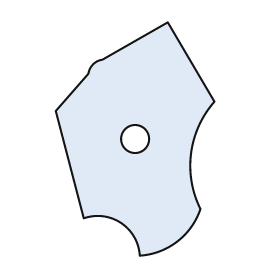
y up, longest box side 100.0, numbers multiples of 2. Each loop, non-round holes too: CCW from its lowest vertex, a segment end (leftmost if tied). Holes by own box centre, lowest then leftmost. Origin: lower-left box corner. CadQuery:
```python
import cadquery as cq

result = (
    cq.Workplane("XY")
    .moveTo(36.0, 0.0)
    .threePointArc((52.0, 6.0), (62.0, 20.0))
    .threePointArc((58.0, 44.0), (68.0, 66.0))
    .lineTo(48.0, 100.0)
    .lineTo(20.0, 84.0)
    .threePointArc((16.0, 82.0), (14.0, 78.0))
    .lineTo(0.0, 62.0)
    .lineTo(12.0, 16.0)
    .threePointArc((28.0, 14.0), (36.0, 0.0))
    .close()
    .moveTo(34.0, 50.0)
    .circle(6.0)
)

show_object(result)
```